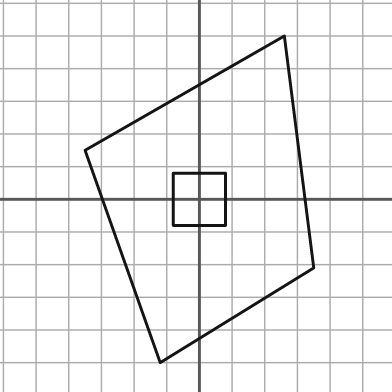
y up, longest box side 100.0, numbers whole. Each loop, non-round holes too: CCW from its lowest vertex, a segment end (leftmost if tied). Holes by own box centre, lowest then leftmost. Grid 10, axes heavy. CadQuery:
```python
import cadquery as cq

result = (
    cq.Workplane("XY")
    .moveTo(-12.0, -50.0)
    .lineTo(35.0, -21.0)
    .lineTo(26.0, 50.0)
    .lineTo(-35.0, 15.0)
    .close()
    .moveTo(-8.0, -8.0)
    .lineTo(8.0, -8.0)
    .lineTo(8.0, 8.0)
    .lineTo(-8.0, 8.0)
    .close()
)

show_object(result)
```